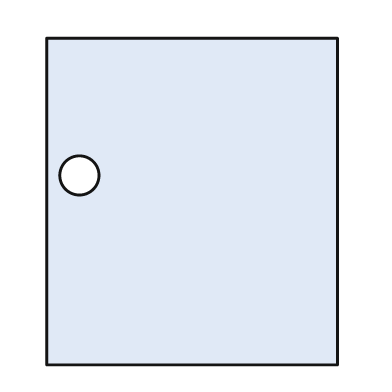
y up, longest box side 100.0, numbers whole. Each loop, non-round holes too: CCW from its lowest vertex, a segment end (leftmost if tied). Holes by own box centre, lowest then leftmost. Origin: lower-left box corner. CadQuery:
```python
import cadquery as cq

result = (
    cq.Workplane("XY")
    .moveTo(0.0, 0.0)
    .lineTo(89.0, 0.0)
    .lineTo(89.0, 100.0)
    .lineTo(0.0, 100.0)
    .close()
    .moveTo(10.0, 58.0)
    .circle(6.0)
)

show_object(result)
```